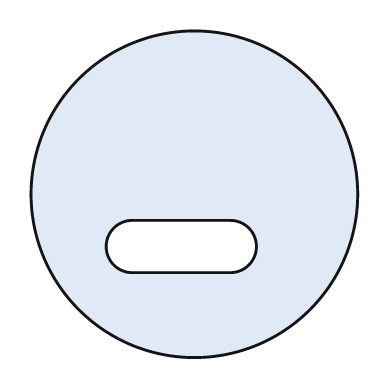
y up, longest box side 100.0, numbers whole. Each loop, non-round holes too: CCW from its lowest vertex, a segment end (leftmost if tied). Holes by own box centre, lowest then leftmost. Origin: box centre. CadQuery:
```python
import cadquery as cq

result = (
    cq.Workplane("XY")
    .moveTo(0.0, 0.0)
    .circle(50.0)
    .moveTo(-19.0, -24.0)
    .lineTo(11.0, -24.0)
    .threePointArc((19.0, -16.0), (11.0, -8.0))
    .lineTo(-19.0, -8.0)
    .threePointArc((-27.0, -16.0), (-19.0, -24.0))
    .close()
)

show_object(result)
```